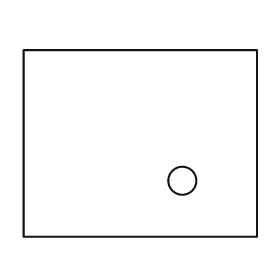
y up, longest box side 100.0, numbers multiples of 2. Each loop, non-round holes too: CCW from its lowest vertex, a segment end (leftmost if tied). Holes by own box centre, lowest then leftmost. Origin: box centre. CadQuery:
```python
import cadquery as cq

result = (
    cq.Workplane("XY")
    .moveTo(-50.0, -40.0)
    .lineTo(50.0, -40.0)
    .lineTo(50.0, 40.0)
    .lineTo(-50.0, 40.0)
    .close()
    .moveTo(18.0, -16.0)
    .circle(6.0)
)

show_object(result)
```